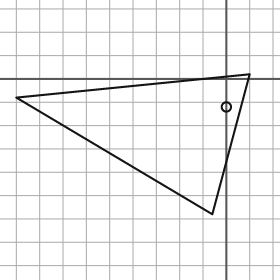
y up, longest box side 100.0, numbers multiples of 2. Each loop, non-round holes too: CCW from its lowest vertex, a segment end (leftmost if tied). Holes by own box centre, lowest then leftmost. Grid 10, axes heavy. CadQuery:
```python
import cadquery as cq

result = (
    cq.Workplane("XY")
    .moveTo(-6.0, -58.0)
    .lineTo(10.0, 2.0)
    .lineTo(-90.0, -8.0)
    .close()
    .moveTo(0.0, -12.0)
    .circle(2.0)
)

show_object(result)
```